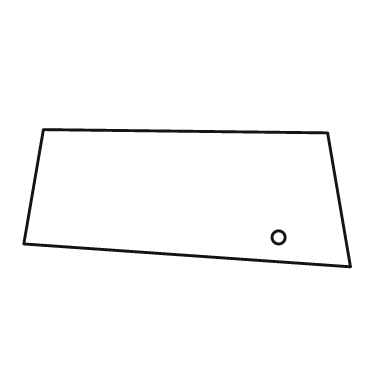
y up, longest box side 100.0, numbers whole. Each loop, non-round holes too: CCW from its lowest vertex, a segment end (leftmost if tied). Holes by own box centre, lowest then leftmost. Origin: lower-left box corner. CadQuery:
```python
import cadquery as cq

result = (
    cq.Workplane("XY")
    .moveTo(100.0, 0.0)
    .lineTo(93.0, 41.0)
    .lineTo(6.0, 42.0)
    .lineTo(0.0, 7.0)
    .close()
    .moveTo(78.0, 9.0)
    .circle(2.0)
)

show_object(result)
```